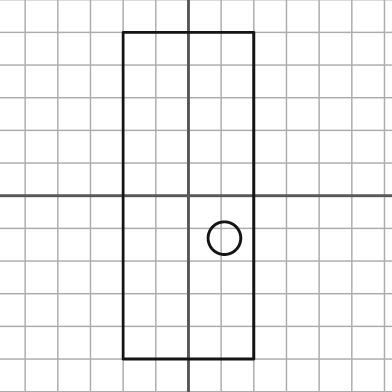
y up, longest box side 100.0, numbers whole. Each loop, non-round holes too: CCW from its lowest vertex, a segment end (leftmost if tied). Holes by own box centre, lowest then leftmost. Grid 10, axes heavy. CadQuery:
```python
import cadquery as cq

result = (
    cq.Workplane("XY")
    .moveTo(-20.0, -50.0)
    .lineTo(20.0, -50.0)
    .lineTo(20.0, 50.0)
    .lineTo(-20.0, 50.0)
    .close()
    .moveTo(11.0, -13.0)
    .circle(5.0)
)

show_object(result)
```